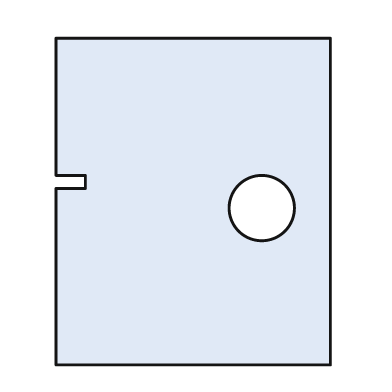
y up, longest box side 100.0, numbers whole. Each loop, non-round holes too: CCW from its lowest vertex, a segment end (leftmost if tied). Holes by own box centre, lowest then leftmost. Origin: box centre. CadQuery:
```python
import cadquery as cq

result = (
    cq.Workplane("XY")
    .moveTo(-42.0, -50.0)
    .lineTo(42.0, -50.0)
    .lineTo(42.0, 50.0)
    .lineTo(-42.0, 50.0)
    .lineTo(-42.0, 8.0)
    .lineTo(-33.0, 8.0)
    .lineTo(-33.0, 4.0)
    .lineTo(-42.0, 4.0)
    .close()
    .moveTo(21.0, -2.0)
    .circle(10.0)
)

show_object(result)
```